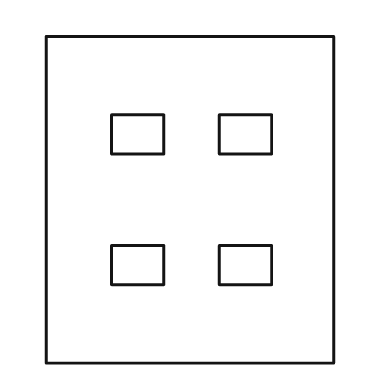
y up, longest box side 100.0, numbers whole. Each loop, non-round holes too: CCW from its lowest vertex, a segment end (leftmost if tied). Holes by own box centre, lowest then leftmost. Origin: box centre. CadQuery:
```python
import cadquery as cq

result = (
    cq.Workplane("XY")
    .moveTo(-44.0, -50.0)
    .lineTo(44.0, -50.0)
    .lineTo(44.0, 50.0)
    .lineTo(-44.0, 50.0)
    .close()
    .moveTo(-24.0, -26.0)
    .lineTo(-8.0, -26.0)
    .lineTo(-8.0, -14.0)
    .lineTo(-24.0, -14.0)
    .close()
    .moveTo(9.0, -26.0)
    .lineTo(25.0, -26.0)
    .lineTo(25.0, -14.0)
    .lineTo(9.0, -14.0)
    .close()
    .moveTo(-24.0, 14.0)
    .lineTo(-8.0, 14.0)
    .lineTo(-8.0, 26.0)
    .lineTo(-24.0, 26.0)
    .close()
    .moveTo(9.0, 14.0)
    .lineTo(25.0, 14.0)
    .lineTo(25.0, 26.0)
    .lineTo(9.0, 26.0)
    .close()
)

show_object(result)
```